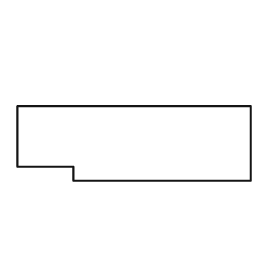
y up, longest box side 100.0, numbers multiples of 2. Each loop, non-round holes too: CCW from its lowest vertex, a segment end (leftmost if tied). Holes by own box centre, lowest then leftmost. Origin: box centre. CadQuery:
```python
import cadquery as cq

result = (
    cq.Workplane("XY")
    .moveTo(-26.0, -16.0)
    .lineTo(50.0, -16.0)
    .lineTo(50.0, 16.0)
    .lineTo(-50.0, 16.0)
    .lineTo(-50.0, -10.0)
    .lineTo(-26.0, -10.0)
    .close()
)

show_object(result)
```